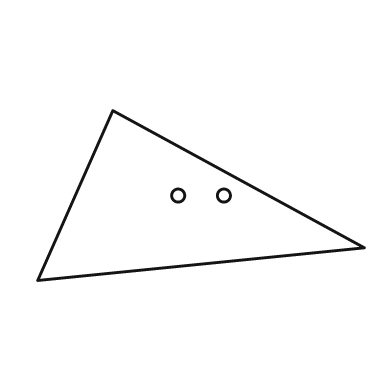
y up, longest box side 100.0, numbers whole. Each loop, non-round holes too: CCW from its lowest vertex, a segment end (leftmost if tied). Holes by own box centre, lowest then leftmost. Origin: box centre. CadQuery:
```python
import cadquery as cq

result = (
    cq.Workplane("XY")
    .moveTo(-50.0, -26.0)
    .lineTo(50.0, -16.0)
    .lineTo(-27.0, 26.0)
    .close()
    .moveTo(-7.0, 0.0)
    .circle(2.0)
    .moveTo(7.0, 0.0)
    .circle(2.0)
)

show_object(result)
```